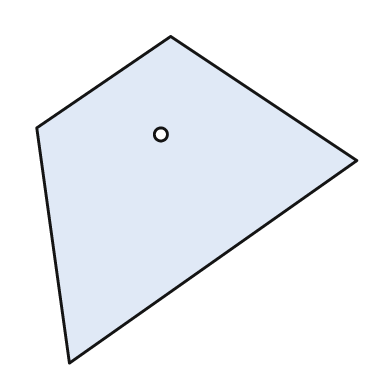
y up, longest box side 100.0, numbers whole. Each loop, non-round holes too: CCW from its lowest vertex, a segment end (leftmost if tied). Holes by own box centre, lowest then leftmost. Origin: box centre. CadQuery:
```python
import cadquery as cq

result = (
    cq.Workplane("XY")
    .moveTo(-39.0, -50.0)
    .lineTo(49.0, 12.0)
    .lineTo(-8.0, 50.0)
    .lineTo(-49.0, 22.0)
    .close()
    .moveTo(-11.0, 20.0)
    .circle(2.0)
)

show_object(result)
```